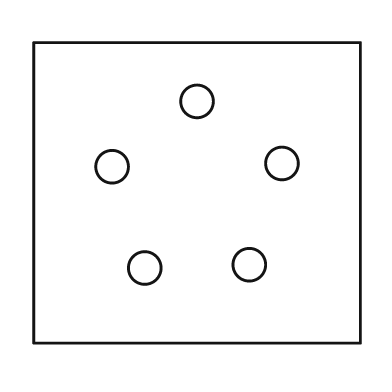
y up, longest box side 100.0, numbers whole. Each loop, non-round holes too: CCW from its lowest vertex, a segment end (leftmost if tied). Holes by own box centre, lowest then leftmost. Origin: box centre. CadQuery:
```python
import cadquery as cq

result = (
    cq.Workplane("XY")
    .moveTo(-50.0, -46.0)
    .lineTo(50.0, -46.0)
    .lineTo(50.0, 46.0)
    .lineTo(-50.0, 46.0)
    .close()
    .moveTo(-16.0, -23.0)
    .circle(5.0)
    .moveTo(16.0, -22.0)
    .circle(5.0)
    .moveTo(-26.0, 8.0)
    .circle(5.0)
    .moveTo(26.0, 9.0)
    .circle(5.0)
    .moveTo(0.0, 28.0)
    .circle(5.0)
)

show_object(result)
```